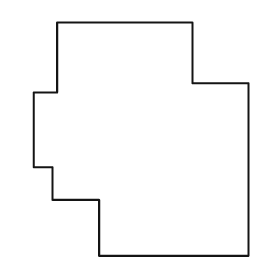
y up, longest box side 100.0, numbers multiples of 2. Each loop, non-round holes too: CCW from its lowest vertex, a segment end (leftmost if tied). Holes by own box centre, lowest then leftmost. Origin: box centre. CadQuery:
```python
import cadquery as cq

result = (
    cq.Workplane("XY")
    .moveTo(-18.0, -50.0)
    .lineTo(46.0, -50.0)
    .lineTo(46.0, 24.0)
    .lineTo(22.0, 24.0)
    .lineTo(22.0, 50.0)
    .lineTo(-36.0, 50.0)
    .lineTo(-36.0, 20.0)
    .lineTo(-46.0, 20.0)
    .lineTo(-46.0, -12.0)
    .lineTo(-38.0, -12.0)
    .lineTo(-38.0, -26.0)
    .lineTo(-18.0, -26.0)
    .close()
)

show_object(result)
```